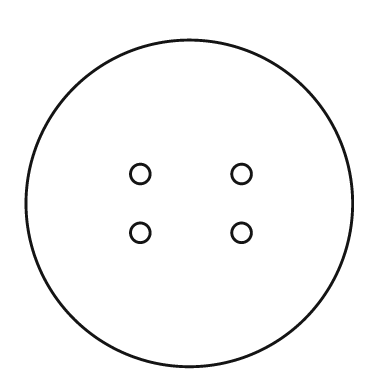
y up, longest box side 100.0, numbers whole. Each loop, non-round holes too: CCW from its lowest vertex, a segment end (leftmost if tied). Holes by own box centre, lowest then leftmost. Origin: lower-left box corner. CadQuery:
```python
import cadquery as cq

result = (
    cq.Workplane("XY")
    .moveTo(50.0, 50.0)
    .circle(50.0)
    .moveTo(35.0, 41.0)
    .circle(3.0)
    .moveTo(66.0, 41.0)
    .circle(3.0)
    .moveTo(35.0, 59.0)
    .circle(3.0)
    .moveTo(66.0, 59.0)
    .circle(3.0)
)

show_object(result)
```